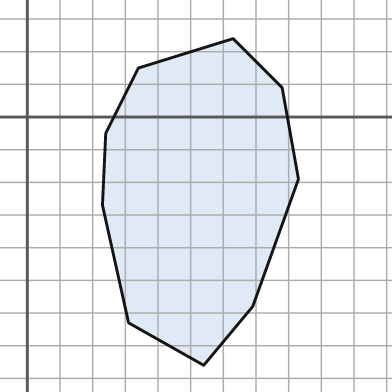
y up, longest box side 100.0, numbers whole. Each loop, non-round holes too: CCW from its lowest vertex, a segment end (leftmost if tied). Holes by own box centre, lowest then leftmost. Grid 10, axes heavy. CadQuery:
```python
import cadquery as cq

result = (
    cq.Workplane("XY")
    .moveTo(54.0, -76.0)
    .lineTo(69.0, -58.0)
    .lineTo(83.0, -19.0)
    .lineTo(78.0, 9.0)
    .lineTo(63.0, 24.0)
    .lineTo(34.0, 15.0)
    .lineTo(24.0, -5.0)
    .lineTo(23.0, -27.0)
    .lineTo(31.0, -63.0)
    .close()
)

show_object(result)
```